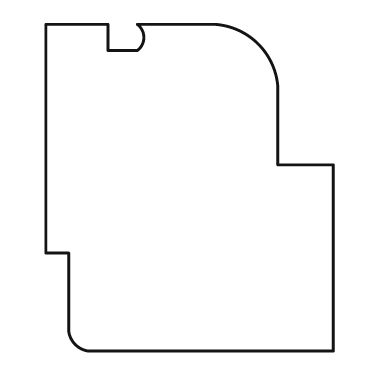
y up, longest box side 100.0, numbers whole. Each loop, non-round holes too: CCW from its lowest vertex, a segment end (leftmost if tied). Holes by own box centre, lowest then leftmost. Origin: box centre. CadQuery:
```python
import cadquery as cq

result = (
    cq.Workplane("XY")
    .moveTo(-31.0, -50.0)
    .lineTo(44.0, -50.0)
    .lineTo(44.0, 7.0)
    .lineTo(27.0, 7.0)
    .lineTo(27.0, 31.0)
    .threePointArc((21.0, 44.0), (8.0, 50.0))
    .lineTo(-16.0, 50.0)
    .threePointArc((-14.0, 46.0), (-16.0, 42.0))
    .lineTo(-25.0, 42.0)
    .lineTo(-25.0, 50.0)
    .lineTo(-44.0, 50.0)
    .lineTo(-44.0, -20.0)
    .lineTo(-37.0, -20.0)
    .lineTo(-37.0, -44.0)
    .threePointArc((-35.0, -48.0), (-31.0, -50.0))
    .close()
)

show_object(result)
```